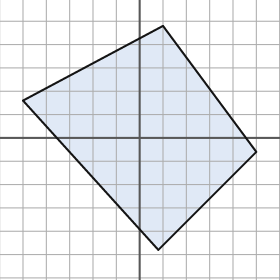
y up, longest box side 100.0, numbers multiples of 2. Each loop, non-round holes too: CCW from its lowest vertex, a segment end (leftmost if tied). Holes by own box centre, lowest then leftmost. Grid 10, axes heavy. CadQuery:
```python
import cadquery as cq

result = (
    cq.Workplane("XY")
    .moveTo(8.0, -48.0)
    .lineTo(50.0, -6.0)
    .lineTo(10.0, 48.0)
    .lineTo(-50.0, 16.0)
    .close()
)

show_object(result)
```